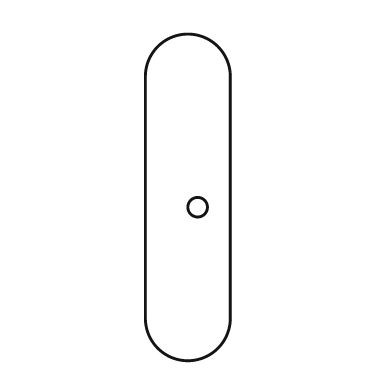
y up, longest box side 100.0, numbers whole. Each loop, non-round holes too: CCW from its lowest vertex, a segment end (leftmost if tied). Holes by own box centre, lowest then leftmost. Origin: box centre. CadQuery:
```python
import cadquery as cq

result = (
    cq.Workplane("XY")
    .moveTo(-13.0, -37.0)
    .threePointArc((0.0, -50.0), (13.0, -37.0))
    .lineTo(13.0, 37.0)
    .threePointArc((0.0, 50.0), (-13.0, 37.0))
    .close()
    .moveTo(3.0, -3.0)
    .circle(3.0)
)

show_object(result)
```